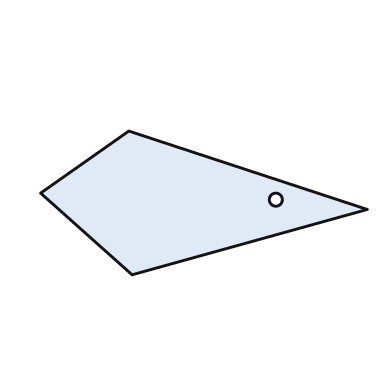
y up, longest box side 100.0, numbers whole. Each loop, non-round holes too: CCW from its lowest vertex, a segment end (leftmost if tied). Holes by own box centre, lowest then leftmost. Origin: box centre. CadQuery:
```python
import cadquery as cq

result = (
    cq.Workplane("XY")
    .moveTo(-22.0, -22.0)
    .lineTo(50.0, -2.0)
    .lineTo(-23.0, 22.0)
    .lineTo(-50.0, 3.0)
    .close()
    .moveTo(22.0, 1.0)
    .circle(2.0)
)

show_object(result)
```